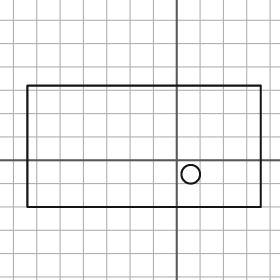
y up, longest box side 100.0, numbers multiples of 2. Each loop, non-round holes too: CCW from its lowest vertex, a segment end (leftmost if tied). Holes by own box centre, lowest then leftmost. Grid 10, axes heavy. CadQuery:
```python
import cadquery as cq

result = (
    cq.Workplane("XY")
    .moveTo(-64.0, -20.0)
    .lineTo(36.0, -20.0)
    .lineTo(36.0, 32.0)
    .lineTo(-64.0, 32.0)
    .close()
    .moveTo(6.0, -6.0)
    .circle(4.0)
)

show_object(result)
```